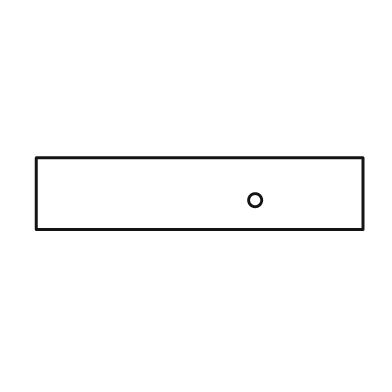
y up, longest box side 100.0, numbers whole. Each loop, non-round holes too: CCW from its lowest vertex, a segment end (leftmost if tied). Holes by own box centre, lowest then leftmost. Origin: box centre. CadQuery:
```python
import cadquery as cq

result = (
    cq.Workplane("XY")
    .moveTo(-50.0, -11.0)
    .lineTo(50.0, -11.0)
    .lineTo(50.0, 11.0)
    .lineTo(-50.0, 11.0)
    .close()
    .moveTo(17.0, -2.0)
    .circle(2.0)
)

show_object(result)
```